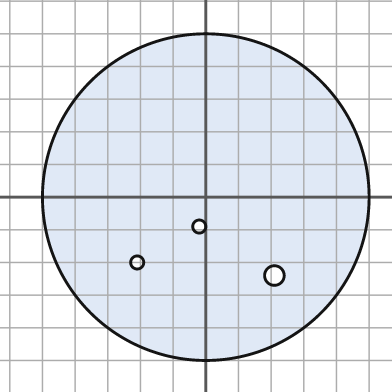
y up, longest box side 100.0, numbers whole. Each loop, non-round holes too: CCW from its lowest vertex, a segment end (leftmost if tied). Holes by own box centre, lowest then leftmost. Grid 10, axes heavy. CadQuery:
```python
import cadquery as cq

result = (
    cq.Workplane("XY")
    .moveTo(0.0, 0.0)
    .circle(50.0)
    .moveTo(21.0, -24.0)
    .circle(3.0)
    .moveTo(-21.0, -20.0)
    .circle(2.0)
    .moveTo(-2.0, -9.0)
    .circle(2.0)
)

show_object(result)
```